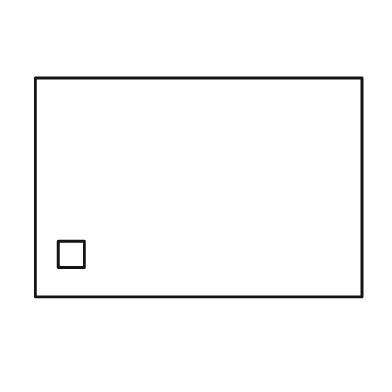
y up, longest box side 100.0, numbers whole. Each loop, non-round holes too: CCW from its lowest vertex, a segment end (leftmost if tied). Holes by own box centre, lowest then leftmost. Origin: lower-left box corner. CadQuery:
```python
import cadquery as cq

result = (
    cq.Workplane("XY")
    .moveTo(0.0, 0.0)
    .lineTo(100.0, 0.0)
    .lineTo(100.0, 67.0)
    .lineTo(0.0, 67.0)
    .close()
    .moveTo(7.0, 9.0)
    .lineTo(15.0, 9.0)
    .lineTo(15.0, 17.0)
    .lineTo(7.0, 17.0)
    .close()
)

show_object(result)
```